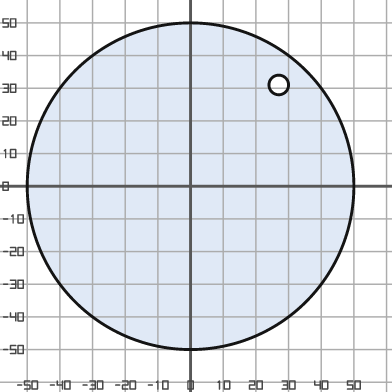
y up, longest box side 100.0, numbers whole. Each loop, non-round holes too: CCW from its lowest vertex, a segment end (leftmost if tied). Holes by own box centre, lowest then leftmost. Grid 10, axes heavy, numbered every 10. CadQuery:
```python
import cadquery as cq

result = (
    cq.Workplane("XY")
    .moveTo(0.0, 0.0)
    .circle(50.0)
    .moveTo(27.0, 31.0)
    .circle(3.0)
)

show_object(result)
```